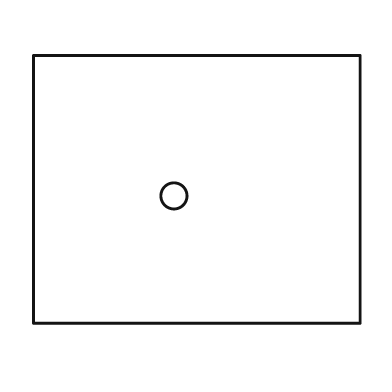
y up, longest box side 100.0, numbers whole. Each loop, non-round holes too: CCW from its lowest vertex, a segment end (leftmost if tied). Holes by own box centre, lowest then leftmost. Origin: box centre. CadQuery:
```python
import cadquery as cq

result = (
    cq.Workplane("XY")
    .moveTo(-50.0, -41.0)
    .lineTo(50.0, -41.0)
    .lineTo(50.0, 41.0)
    .lineTo(-50.0, 41.0)
    .close()
    .moveTo(-7.0, -2.0)
    .circle(4.0)
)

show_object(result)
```